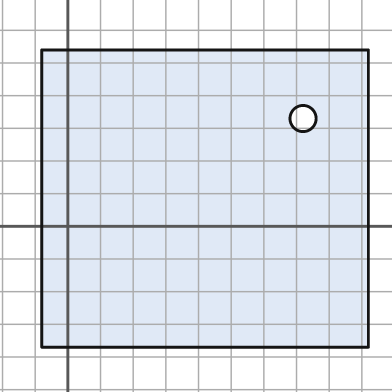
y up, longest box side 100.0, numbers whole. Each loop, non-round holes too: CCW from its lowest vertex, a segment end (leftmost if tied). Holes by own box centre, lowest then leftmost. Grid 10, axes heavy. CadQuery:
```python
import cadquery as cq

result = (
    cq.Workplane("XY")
    .moveTo(-8.0, -37.0)
    .lineTo(92.0, -37.0)
    .lineTo(92.0, 54.0)
    .lineTo(-8.0, 54.0)
    .close()
    .moveTo(72.0, 33.0)
    .circle(4.0)
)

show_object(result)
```